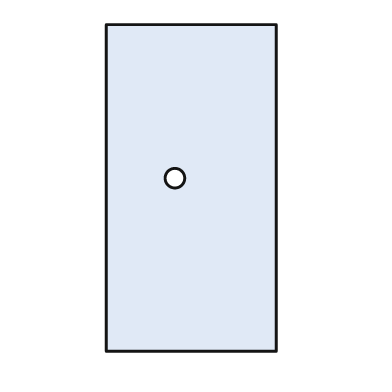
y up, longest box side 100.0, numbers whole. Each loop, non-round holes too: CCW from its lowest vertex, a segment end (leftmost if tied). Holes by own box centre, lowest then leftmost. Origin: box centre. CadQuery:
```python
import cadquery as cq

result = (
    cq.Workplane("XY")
    .moveTo(-26.0, -50.0)
    .lineTo(26.0, -50.0)
    .lineTo(26.0, 50.0)
    .lineTo(-26.0, 50.0)
    .close()
    .moveTo(-5.0, 3.0)
    .circle(3.0)
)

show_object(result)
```